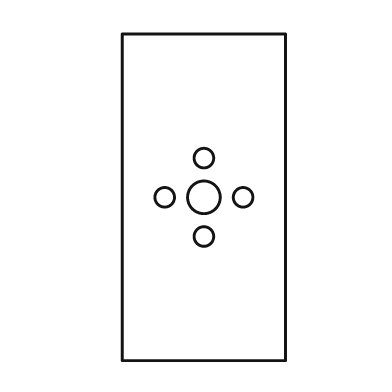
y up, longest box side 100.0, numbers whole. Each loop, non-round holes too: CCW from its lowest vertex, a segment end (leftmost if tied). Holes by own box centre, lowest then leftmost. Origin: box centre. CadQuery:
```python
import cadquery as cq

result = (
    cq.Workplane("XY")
    .moveTo(-25.0, -50.0)
    .lineTo(25.0, -50.0)
    .lineTo(25.0, 50.0)
    .lineTo(-25.0, 50.0)
    .close()
    .moveTo(0.0, -12.0)
    .circle(3.0)
    .moveTo(-12.0, 0.0)
    .circle(3.0)
    .moveTo(0.0, 0.0)
    .circle(5.0)
    .moveTo(12.0, 0.0)
    .circle(3.0)
    .moveTo(0.0, 12.0)
    .circle(3.0)
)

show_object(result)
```